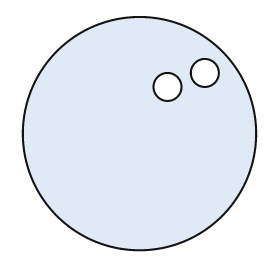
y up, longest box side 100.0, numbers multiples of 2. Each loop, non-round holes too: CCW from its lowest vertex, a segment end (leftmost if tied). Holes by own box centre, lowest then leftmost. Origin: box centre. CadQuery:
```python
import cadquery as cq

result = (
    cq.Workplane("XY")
    .moveTo(0.0, 0.0)
    .circle(50.0)
    .moveTo(12.0, 20.0)
    .circle(6.0)
    .moveTo(28.0, 26.0)
    .circle(6.0)
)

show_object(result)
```